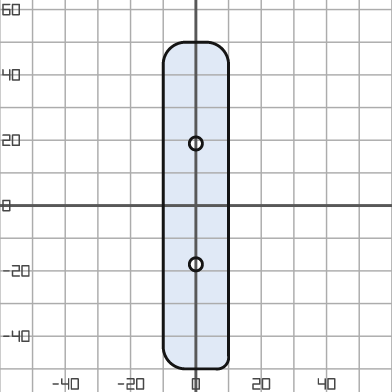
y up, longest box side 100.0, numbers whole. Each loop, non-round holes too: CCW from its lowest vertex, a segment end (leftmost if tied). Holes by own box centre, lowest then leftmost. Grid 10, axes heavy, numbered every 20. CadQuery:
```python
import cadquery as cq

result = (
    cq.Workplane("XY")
    .moveTo(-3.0, -50.0)
    .lineTo(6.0, -50.0)
    .threePointArc((9.0, -49.0), (10.0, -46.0))
    .lineTo(10.0, 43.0)
    .threePointArc((8.0, 48.0), (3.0, 50.0))
    .lineTo(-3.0, 50.0)
    .threePointArc((-8.0, 48.0), (-10.0, 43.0))
    .lineTo(-10.0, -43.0)
    .threePointArc((-8.0, -48.0), (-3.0, -50.0))
    .close()
    .moveTo(0.0, -18.0)
    .circle(2.0)
    .moveTo(0.0, 19.0)
    .circle(2.0)
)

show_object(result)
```